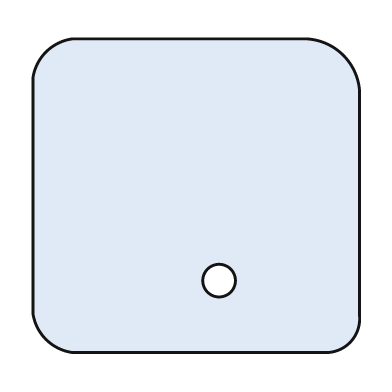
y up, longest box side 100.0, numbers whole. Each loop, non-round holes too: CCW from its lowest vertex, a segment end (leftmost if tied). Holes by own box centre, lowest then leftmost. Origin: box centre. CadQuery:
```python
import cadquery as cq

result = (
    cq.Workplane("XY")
    .moveTo(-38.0, -48.0)
    .lineTo(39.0, -48.0)
    .threePointArc((47.0, -45.0), (50.0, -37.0))
    .lineTo(50.0, 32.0)
    .threePointArc((45.0, 43.0), (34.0, 48.0))
    .lineTo(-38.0, 48.0)
    .threePointArc((-46.0, 44.0), (-50.0, 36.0))
    .lineTo(-50.0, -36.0)
    .threePointArc((-46.0, -44.0), (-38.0, -48.0))
    .close()
    .moveTo(7.0, -26.0)
    .circle(5.0)
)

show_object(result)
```